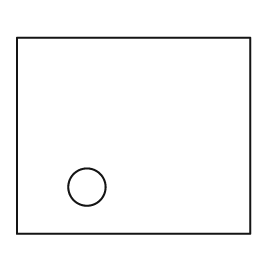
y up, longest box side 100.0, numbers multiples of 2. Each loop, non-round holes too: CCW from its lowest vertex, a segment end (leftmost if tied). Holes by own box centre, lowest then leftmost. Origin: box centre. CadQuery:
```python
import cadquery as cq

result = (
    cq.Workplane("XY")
    .moveTo(-50.0, -42.0)
    .lineTo(50.0, -42.0)
    .lineTo(50.0, 42.0)
    .lineTo(-50.0, 42.0)
    .close()
    .moveTo(-20.0, -22.0)
    .circle(8.0)
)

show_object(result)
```